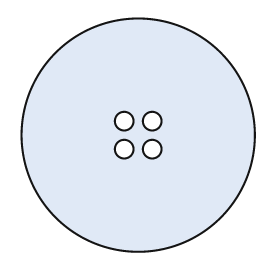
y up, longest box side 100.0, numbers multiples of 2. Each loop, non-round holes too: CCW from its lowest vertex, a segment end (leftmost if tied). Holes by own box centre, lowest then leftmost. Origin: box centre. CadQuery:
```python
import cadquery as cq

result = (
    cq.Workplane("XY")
    .moveTo(0.0, 0.0)
    .circle(50.0)
    .moveTo(-6.0, -6.0)
    .circle(4.0)
    .moveTo(6.0, -6.0)
    .circle(4.0)
    .moveTo(-6.0, 6.0)
    .circle(4.0)
    .moveTo(6.0, 6.0)
    .circle(4.0)
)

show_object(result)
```